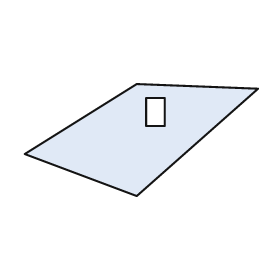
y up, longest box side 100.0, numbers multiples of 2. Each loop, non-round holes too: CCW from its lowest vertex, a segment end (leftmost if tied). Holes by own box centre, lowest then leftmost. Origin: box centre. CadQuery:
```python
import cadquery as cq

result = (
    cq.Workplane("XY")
    .moveTo(-2.0, -24.0)
    .lineTo(50.0, 22.0)
    .lineTo(-2.0, 24.0)
    .lineTo(-50.0, -6.0)
    .close()
    .moveTo(2.0, 6.0)
    .lineTo(10.0, 6.0)
    .lineTo(10.0, 18.0)
    .lineTo(2.0, 18.0)
    .close()
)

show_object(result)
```